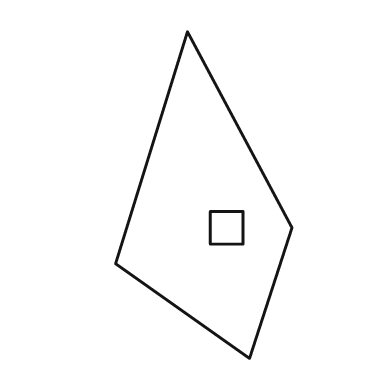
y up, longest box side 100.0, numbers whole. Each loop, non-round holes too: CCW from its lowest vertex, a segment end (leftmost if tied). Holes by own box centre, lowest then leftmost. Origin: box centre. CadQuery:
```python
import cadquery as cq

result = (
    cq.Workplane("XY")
    .moveTo(14.0, -50.0)
    .lineTo(27.0, -10.0)
    .lineTo(-5.0, 50.0)
    .lineTo(-27.0, -21.0)
    .close()
    .moveTo(2.0, -15.0)
    .lineTo(12.0, -15.0)
    .lineTo(12.0, -5.0)
    .lineTo(2.0, -5.0)
    .close()
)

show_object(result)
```